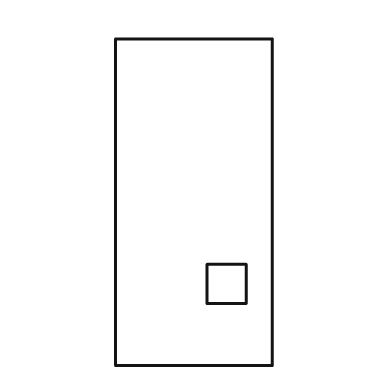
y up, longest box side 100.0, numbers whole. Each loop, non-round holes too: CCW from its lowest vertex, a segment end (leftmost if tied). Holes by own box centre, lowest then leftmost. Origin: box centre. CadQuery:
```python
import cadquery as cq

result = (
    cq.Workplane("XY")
    .moveTo(-24.0, -50.0)
    .lineTo(24.0, -50.0)
    .lineTo(24.0, 50.0)
    .lineTo(-24.0, 50.0)
    .close()
    .moveTo(4.0, -31.0)
    .lineTo(16.0, -31.0)
    .lineTo(16.0, -19.0)
    .lineTo(4.0, -19.0)
    .close()
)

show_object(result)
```